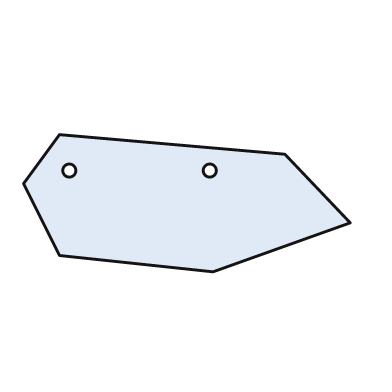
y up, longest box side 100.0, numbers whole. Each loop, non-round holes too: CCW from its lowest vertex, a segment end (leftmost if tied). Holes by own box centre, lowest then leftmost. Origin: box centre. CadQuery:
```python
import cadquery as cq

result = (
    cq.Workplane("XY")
    .moveTo(8.0, -21.0)
    .lineTo(50.0, -6.0)
    .lineTo(30.0, 15.0)
    .lineTo(-39.0, 21.0)
    .lineTo(-50.0, 6.0)
    .lineTo(-39.0, -16.0)
    .close()
    .moveTo(-36.0, 10.0)
    .circle(2.0)
    .moveTo(7.0, 10.0)
    .circle(2.0)
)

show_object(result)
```